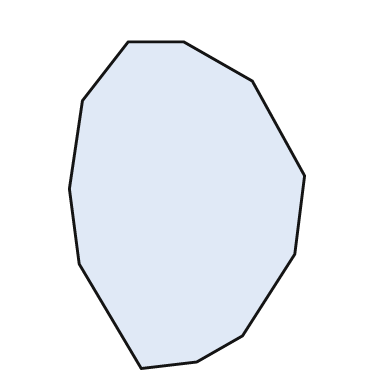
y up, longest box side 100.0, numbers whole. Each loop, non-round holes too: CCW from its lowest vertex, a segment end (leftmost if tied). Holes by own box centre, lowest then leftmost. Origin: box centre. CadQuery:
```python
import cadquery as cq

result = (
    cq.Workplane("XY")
    .moveTo(-14.0, -50.0)
    .lineTo(3.0, -48.0)
    .lineTo(17.0, -40.0)
    .lineTo(33.0, -15.0)
    .lineTo(36.0, 9.0)
    .lineTo(20.0, 38.0)
    .lineTo(-1.0, 50.0)
    .lineTo(-18.0, 50.0)
    .lineTo(-32.0, 32.0)
    .lineTo(-36.0, 5.0)
    .lineTo(-33.0, -18.0)
    .close()
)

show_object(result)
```